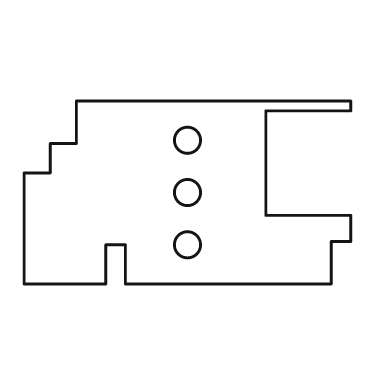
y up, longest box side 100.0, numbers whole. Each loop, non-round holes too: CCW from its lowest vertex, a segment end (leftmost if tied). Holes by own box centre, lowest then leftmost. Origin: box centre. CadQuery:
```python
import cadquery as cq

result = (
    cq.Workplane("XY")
    .moveTo(-50.0, -28.0)
    .lineTo(-25.0, -28.0)
    .lineTo(-25.0, -16.0)
    .lineTo(-19.0, -16.0)
    .lineTo(-19.0, -28.0)
    .lineTo(44.0, -28.0)
    .lineTo(44.0, -15.0)
    .lineTo(50.0, -15.0)
    .lineTo(50.0, -7.0)
    .lineTo(24.0, -7.0)
    .lineTo(24.0, 25.0)
    .lineTo(50.0, 25.0)
    .lineTo(50.0, 28.0)
    .lineTo(-34.0, 28.0)
    .lineTo(-34.0, 15.0)
    .lineTo(-42.0, 15.0)
    .lineTo(-42.0, 6.0)
    .lineTo(-50.0, 6.0)
    .close()
    .moveTo(0.0, -16.0)
    .circle(4.0)
    .moveTo(0.0, 0.0)
    .circle(4.0)
    .moveTo(0.0, 16.0)
    .circle(4.0)
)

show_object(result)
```